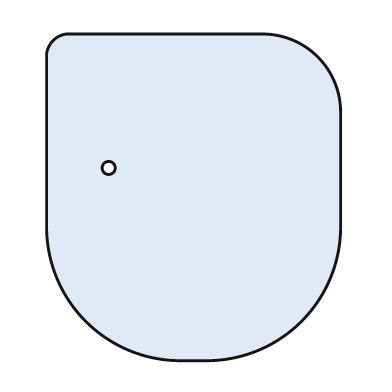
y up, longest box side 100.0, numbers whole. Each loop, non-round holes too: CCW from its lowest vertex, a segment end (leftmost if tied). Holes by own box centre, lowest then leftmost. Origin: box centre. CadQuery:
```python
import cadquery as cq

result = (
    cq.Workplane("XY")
    .moveTo(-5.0, -50.0)
    .lineTo(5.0, -50.0)
    .threePointArc((33.0, -38.0), (45.0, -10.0))
    .lineTo(45.0, 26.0)
    .threePointArc((38.0, 43.0), (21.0, 50.0))
    .lineTo(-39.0, 50.0)
    .threePointArc((-43.0, 48.0), (-45.0, 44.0))
    .lineTo(-45.0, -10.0)
    .threePointArc((-33.0, -38.0), (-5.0, -50.0))
    .close()
    .moveTo(-26.0, 9.0)
    .circle(2.0)
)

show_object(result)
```